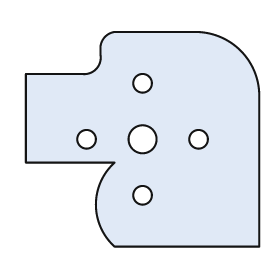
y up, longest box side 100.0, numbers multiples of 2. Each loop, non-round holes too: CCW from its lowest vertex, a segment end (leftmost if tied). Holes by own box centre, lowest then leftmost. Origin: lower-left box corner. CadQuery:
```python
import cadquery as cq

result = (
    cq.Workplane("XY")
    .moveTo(38.0, 0.0)
    .lineTo(100.0, 0.0)
    .lineTo(100.0, 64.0)
    .threePointArc((92.0, 84.0), (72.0, 92.0))
    .lineTo(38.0, 92.0)
    .threePointArc((34.0, 90.0), (32.0, 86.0))
    .lineTo(32.0, 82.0)
    .threePointArc((30.0, 76.0), (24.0, 74.0))
    .lineTo(0.0, 74.0)
    .lineTo(0.0, 36.0)
    .lineTo(38.0, 36.0)
    .threePointArc((30.0, 18.0), (38.0, 0.0))
    .close()
    .moveTo(50.0, 22.0)
    .circle(4.0)
    .moveTo(26.0, 46.0)
    .circle(4.0)
    .moveTo(50.0, 46.0)
    .circle(6.0)
    .moveTo(74.0, 46.0)
    .circle(4.0)
    .moveTo(50.0, 70.0)
    .circle(4.0)
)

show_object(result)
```